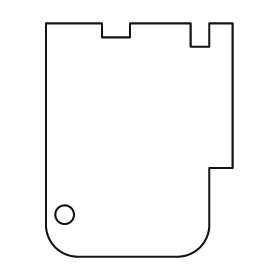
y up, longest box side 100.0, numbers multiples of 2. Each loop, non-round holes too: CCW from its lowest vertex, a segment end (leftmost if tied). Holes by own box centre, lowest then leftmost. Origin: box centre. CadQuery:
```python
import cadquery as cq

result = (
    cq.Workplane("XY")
    .moveTo(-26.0, -50.0)
    .lineTo(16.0, -50.0)
    .threePointArc((26.0, -46.0), (30.0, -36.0))
    .lineTo(30.0, -12.0)
    .lineTo(40.0, -12.0)
    .lineTo(40.0, 50.0)
    .lineTo(30.0, 50.0)
    .lineTo(30.0, 40.0)
    .lineTo(22.0, 40.0)
    .lineTo(22.0, 50.0)
    .lineTo(-4.0, 50.0)
    .lineTo(-4.0, 44.0)
    .lineTo(-16.0, 44.0)
    .lineTo(-16.0, 50.0)
    .lineTo(-40.0, 50.0)
    .lineTo(-40.0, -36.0)
    .threePointArc((-36.0, -46.0), (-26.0, -50.0))
    .close()
    .moveTo(-32.0, -32.0)
    .circle(4.0)
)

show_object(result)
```